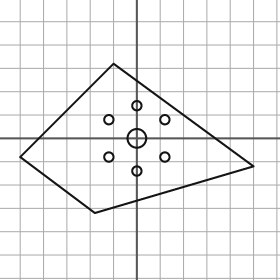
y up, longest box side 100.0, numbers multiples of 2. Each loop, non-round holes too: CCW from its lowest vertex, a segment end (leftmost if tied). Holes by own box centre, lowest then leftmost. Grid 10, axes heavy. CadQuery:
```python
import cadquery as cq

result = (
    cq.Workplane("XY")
    .moveTo(-18.0, -32.0)
    .lineTo(50.0, -12.0)
    .lineTo(-10.0, 32.0)
    .lineTo(-50.0, -8.0)
    .close()
    .moveTo(0.0, -14.0)
    .circle(2.0)
    .moveTo(-12.0, -8.0)
    .circle(2.0)
    .moveTo(12.0, -8.0)
    .circle(2.0)
    .moveTo(0.0, 0.0)
    .circle(4.0)
    .moveTo(-12.0, 8.0)
    .circle(2.0)
    .moveTo(12.0, 8.0)
    .circle(2.0)
    .moveTo(0.0, 14.0)
    .circle(2.0)
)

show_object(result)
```